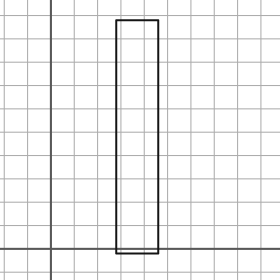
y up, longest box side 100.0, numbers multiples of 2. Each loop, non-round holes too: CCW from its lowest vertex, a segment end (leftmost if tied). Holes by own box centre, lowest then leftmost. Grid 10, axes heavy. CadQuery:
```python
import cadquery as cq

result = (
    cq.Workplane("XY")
    .moveTo(28.0, -2.0)
    .lineTo(46.0, -2.0)
    .lineTo(46.0, 98.0)
    .lineTo(28.0, 98.0)
    .close()
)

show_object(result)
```